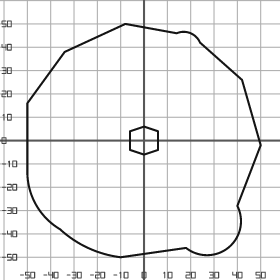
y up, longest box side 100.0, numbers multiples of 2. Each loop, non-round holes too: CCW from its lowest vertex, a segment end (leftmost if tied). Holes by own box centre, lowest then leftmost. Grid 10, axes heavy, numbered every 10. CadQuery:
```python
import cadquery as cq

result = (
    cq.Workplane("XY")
    .moveTo(-10.0, -50.0)
    .lineTo(18.0, -46.0)
    .threePointArc((36.0, -46.0), (40.0, -28.0))
    .lineTo(50.0, -2.0)
    .lineTo(42.0, 26.0)
    .lineTo(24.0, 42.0)
    .threePointArc((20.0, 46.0), (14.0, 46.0))
    .lineTo(-8.0, 50.0)
    .lineTo(-34.0, 38.0)
    .lineTo(-50.0, 16.0)
    .lineTo(-50.0, -14.0)
    .threePointArc((-46.0, -28.0), (-36.0, -38.0))
    .threePointArc((-24.0, -46.0), (-10.0, -50.0))
    .close()
    .moveTo(0.0, -6.0)
    .lineTo(6.0, -4.0)
    .lineTo(6.0, 4.0)
    .lineTo(0.0, 6.0)
    .lineTo(-6.0, 4.0)
    .lineTo(-6.0, -4.0)
    .close()
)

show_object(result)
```